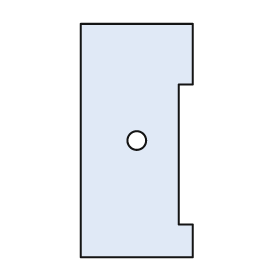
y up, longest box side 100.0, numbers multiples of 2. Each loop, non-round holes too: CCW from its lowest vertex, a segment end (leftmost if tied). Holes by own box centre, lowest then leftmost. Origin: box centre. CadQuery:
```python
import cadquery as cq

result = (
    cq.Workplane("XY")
    .moveTo(-24.0, -50.0)
    .lineTo(24.0, -50.0)
    .lineTo(24.0, -36.0)
    .lineTo(18.0, -36.0)
    .lineTo(18.0, 24.0)
    .lineTo(24.0, 24.0)
    .lineTo(24.0, 50.0)
    .lineTo(-24.0, 50.0)
    .close()
    .moveTo(0.0, 0.0)
    .circle(4.0)
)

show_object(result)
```